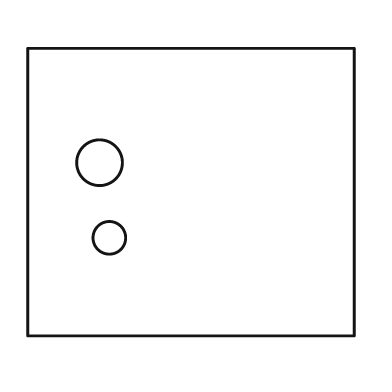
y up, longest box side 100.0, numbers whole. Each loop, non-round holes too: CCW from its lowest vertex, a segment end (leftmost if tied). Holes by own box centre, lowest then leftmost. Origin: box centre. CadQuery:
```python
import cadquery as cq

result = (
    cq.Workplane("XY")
    .moveTo(-50.0, -44.0)
    .lineTo(50.0, -44.0)
    .lineTo(50.0, 44.0)
    .lineTo(-50.0, 44.0)
    .close()
    .moveTo(-25.0, -14.0)
    .circle(5.0)
    .moveTo(-28.0, 9.0)
    .circle(7.0)
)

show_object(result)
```